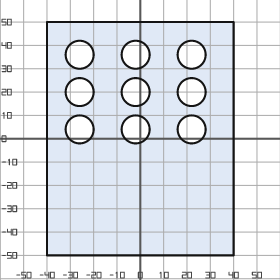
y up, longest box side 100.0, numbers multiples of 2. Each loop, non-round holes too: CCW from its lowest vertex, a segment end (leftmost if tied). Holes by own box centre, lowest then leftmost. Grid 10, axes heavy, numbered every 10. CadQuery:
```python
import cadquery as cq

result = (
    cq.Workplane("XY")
    .moveTo(-40.0, -50.0)
    .lineTo(40.0, -50.0)
    .lineTo(40.0, 50.0)
    .lineTo(-40.0, 50.0)
    .close()
    .moveTo(-26.0, 4.0)
    .circle(6.0)
    .moveTo(-2.0, 4.0)
    .circle(6.0)
    .moveTo(22.0, 4.0)
    .circle(6.0)
    .moveTo(-26.0, 20.0)
    .circle(6.0)
    .moveTo(-2.0, 20.0)
    .circle(6.0)
    .moveTo(22.0, 20.0)
    .circle(6.0)
    .moveTo(-26.0, 36.0)
    .circle(6.0)
    .moveTo(-2.0, 36.0)
    .circle(6.0)
    .moveTo(22.0, 36.0)
    .circle(6.0)
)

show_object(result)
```